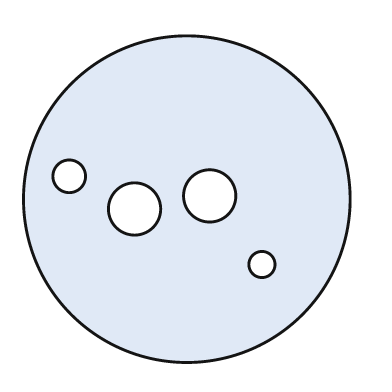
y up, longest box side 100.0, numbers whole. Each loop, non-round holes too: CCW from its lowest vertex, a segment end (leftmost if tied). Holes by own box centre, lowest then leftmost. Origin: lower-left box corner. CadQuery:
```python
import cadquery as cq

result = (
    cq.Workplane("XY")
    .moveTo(50.0, 50.0)
    .circle(50.0)
    .moveTo(73.0, 30.0)
    .circle(4.0)
    .moveTo(34.0, 47.0)
    .circle(8.0)
    .moveTo(57.0, 51.0)
    .circle(8.0)
    .moveTo(14.0, 57.0)
    .circle(5.0)
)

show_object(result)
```